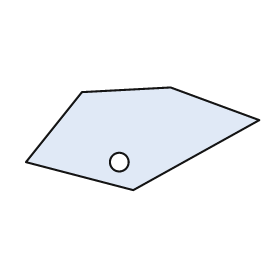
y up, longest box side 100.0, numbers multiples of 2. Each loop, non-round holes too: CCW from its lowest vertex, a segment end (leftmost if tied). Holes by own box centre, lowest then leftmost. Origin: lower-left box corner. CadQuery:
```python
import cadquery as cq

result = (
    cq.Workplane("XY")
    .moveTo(46.0, 0.0)
    .lineTo(100.0, 30.0)
    .lineTo(62.0, 44.0)
    .lineTo(24.0, 42.0)
    .lineTo(0.0, 12.0)
    .close()
    .moveTo(40.0, 12.0)
    .circle(4.0)
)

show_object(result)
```